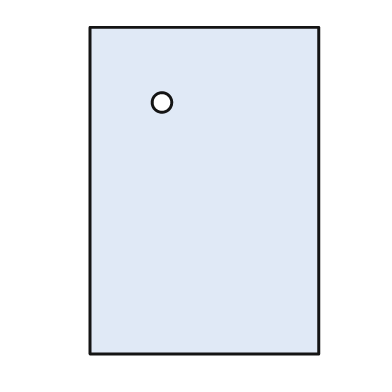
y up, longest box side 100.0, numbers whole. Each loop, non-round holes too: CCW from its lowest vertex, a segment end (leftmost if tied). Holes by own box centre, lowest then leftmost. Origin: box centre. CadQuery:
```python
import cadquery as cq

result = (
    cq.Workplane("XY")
    .moveTo(-35.0, -50.0)
    .lineTo(35.0, -50.0)
    .lineTo(35.0, 50.0)
    .lineTo(-35.0, 50.0)
    .close()
    .moveTo(-13.0, 27.0)
    .circle(3.0)
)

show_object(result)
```